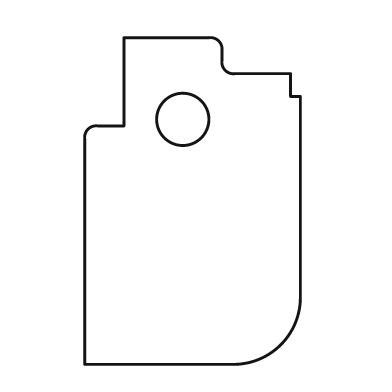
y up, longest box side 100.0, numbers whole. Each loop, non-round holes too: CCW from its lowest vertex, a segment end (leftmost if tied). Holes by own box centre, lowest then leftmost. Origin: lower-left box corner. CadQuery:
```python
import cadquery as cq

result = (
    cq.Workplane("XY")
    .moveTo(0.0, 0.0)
    .lineTo(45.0, 0.0)
    .threePointArc((60.0, 6.0), (66.0, 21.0))
    .lineTo(66.0, 82.0)
    .lineTo(63.0, 82.0)
    .lineTo(63.0, 89.0)
    .lineTo(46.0, 89.0)
    .threePointArc((43.0, 90.0), (42.0, 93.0))
    .lineTo(42.0, 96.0)
    .threePointArc((41.0, 99.0), (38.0, 100.0))
    .lineTo(12.0, 100.0)
    .lineTo(12.0, 73.0)
    .lineTo(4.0, 73.0)
    .threePointArc((1.0, 72.0), (0.0, 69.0))
    .close()
    .moveTo(30.0, 75.0)
    .circle(8.0)
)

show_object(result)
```